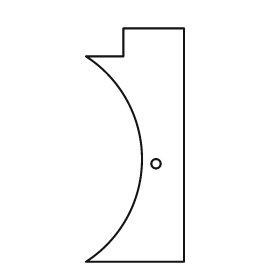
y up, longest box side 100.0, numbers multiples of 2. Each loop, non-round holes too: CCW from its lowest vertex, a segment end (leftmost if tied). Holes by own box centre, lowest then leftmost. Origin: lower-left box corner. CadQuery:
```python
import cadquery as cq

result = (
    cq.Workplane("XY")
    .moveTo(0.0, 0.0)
    .lineTo(42.0, 0.0)
    .lineTo(42.0, 100.0)
    .lineTo(16.0, 100.0)
    .lineTo(16.0, 88.0)
    .lineTo(0.0, 88.0)
    .threePointArc((24.0, 44.0), (0.0, 0.0))
    .close()
    .moveTo(30.0, 42.0)
    .circle(2.0)
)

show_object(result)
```